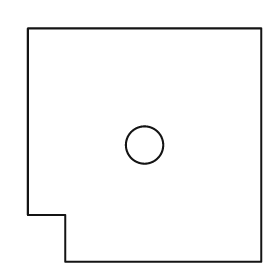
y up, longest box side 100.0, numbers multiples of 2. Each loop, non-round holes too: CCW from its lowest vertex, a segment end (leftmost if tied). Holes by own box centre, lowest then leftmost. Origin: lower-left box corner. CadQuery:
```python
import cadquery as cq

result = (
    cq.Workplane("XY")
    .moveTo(16.0, 0.0)
    .lineTo(100.0, 0.0)
    .lineTo(100.0, 100.0)
    .lineTo(0.0, 100.0)
    .lineTo(0.0, 20.0)
    .lineTo(16.0, 20.0)
    .close()
    .moveTo(50.0, 50.0)
    .circle(8.0)
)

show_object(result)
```